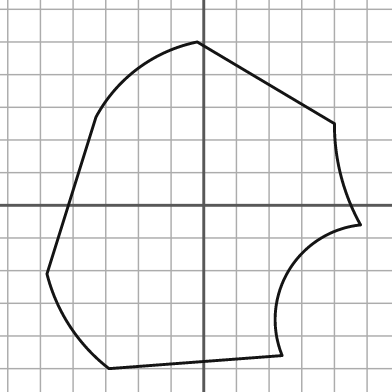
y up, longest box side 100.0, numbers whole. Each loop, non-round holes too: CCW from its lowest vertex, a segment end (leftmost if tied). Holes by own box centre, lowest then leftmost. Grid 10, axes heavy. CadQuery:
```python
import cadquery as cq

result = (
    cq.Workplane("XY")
    .moveTo(-29.0, -50.0)
    .lineTo(24.0, -46.0)
    .threePointArc((26.0, -20.0), (48.0, -6.0))
    .threePointArc((42.0, 9.0), (40.0, 25.0))
    .lineTo(-2.0, 50.0)
    .threePointArc((-20.0, 42.0), (-33.0, 27.0))
    .lineTo(-48.0, -21.0)
    .threePointArc((-41.0, -37.0), (-29.0, -50.0))
    .close()
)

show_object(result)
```